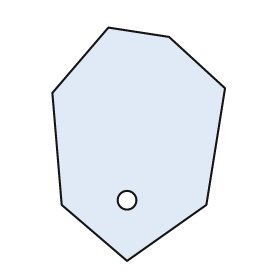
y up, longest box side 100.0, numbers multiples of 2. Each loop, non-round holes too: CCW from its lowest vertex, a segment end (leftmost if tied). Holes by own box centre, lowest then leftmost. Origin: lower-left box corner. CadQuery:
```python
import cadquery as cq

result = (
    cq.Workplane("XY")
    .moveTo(32.0, 0.0)
    .lineTo(66.0, 24.0)
    .lineTo(74.0, 74.0)
    .lineTo(50.0, 96.0)
    .lineTo(24.0, 100.0)
    .lineTo(0.0, 72.0)
    .lineTo(4.0, 24.0)
    .close()
    .moveTo(32.0, 26.0)
    .circle(4.0)
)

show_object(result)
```